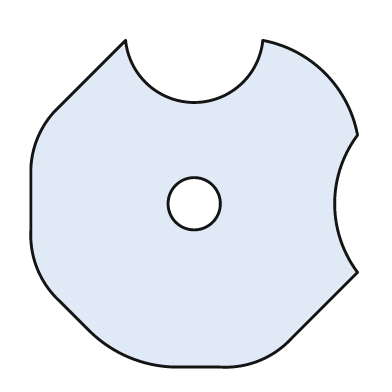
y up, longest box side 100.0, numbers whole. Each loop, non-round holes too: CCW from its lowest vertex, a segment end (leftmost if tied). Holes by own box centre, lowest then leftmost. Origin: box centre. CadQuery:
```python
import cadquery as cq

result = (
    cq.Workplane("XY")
    .moveTo(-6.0, -50.0)
    .lineTo(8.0, -50.0)
    .threePointArc((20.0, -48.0), (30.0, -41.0))
    .lineTo(50.0, -21.0)
    .threePointArc((43.0, 0.0), (50.0, 21.0))
    .threePointArc((40.0, 40.0), (21.0, 50.0))
    .threePointArc((0.0, 31.0), (-21.0, 50.0))
    .lineTo(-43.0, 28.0)
    .threePointArc((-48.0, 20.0), (-50.0, 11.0))
    .lineTo(-50.0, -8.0)
    .threePointArc((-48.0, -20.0), (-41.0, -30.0))
    .lineTo(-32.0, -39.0)
    .threePointArc((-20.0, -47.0), (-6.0, -50.0))
    .close()
    .moveTo(0.0, 0.0)
    .circle(8.0)
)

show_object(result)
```